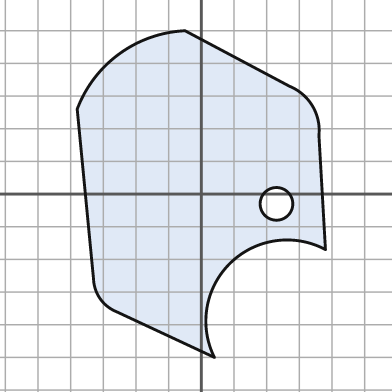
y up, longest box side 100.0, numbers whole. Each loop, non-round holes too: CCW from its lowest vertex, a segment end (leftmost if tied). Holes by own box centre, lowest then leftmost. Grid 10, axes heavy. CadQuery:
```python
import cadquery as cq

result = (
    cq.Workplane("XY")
    .moveTo(4.0, -50.0)
    .threePointArc((9.0, -21.0), (38.0, -17.0))
    .lineTo(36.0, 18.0)
    .threePointArc((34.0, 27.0), (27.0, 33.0))
    .lineTo(-5.0, 50.0)
    .threePointArc((-25.0, 43.0), (-38.0, 26.0))
    .lineTo(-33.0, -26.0)
    .threePointArc((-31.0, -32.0), (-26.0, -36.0))
    .close()
    .moveTo(23.0, -3.0)
    .circle(5.0)
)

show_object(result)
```